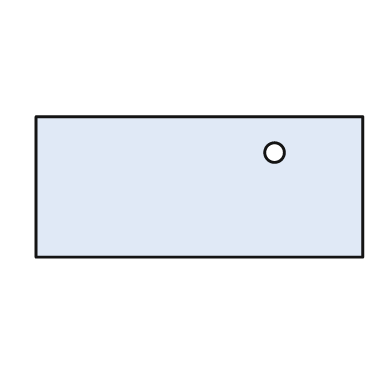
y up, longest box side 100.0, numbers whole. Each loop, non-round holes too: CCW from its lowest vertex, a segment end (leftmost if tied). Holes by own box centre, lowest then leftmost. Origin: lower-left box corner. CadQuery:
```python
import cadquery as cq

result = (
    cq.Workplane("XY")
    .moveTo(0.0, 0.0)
    .lineTo(100.0, 0.0)
    .lineTo(100.0, 43.0)
    .lineTo(0.0, 43.0)
    .close()
    .moveTo(73.0, 32.0)
    .circle(3.0)
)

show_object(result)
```